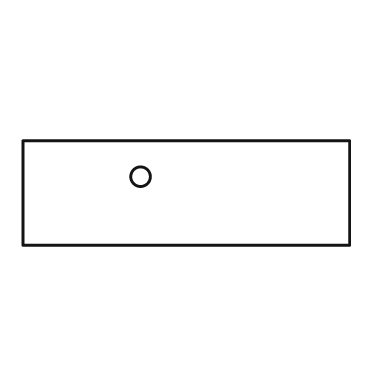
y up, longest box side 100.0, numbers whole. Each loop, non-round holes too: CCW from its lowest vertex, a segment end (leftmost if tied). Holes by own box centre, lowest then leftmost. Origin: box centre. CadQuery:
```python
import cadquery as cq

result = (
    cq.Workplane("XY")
    .moveTo(-50.0, -16.0)
    .lineTo(50.0, -16.0)
    .lineTo(50.0, 16.0)
    .lineTo(-50.0, 16.0)
    .close()
    .moveTo(-14.0, 5.0)
    .circle(3.0)
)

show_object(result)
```